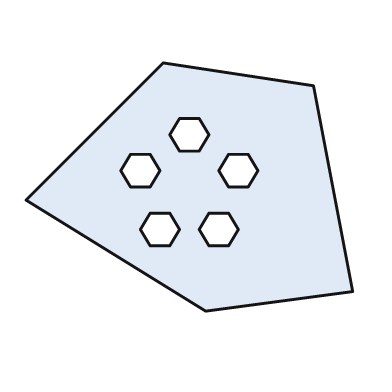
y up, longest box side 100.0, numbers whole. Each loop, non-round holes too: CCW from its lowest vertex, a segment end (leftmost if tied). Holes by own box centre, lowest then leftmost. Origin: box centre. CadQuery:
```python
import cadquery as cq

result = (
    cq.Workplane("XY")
    .moveTo(5.0, -38.0)
    .lineTo(50.0, -32.0)
    .lineTo(38.0, 31.0)
    .lineTo(-8.0, 38.0)
    .lineTo(-50.0, -4.0)
    .close()
    .moveTo(-12.0, -18.0)
    .lineTo(-6.0, -18.0)
    .lineTo(-3.0, -13.0)
    .lineTo(-6.0, -8.0)
    .lineTo(-12.0, -8.0)
    .lineTo(-15.0, -13.0)
    .close()
    .moveTo(6.0, -18.0)
    .lineTo(12.0, -18.0)
    .lineTo(15.0, -13.0)
    .lineTo(12.0, -8.0)
    .lineTo(6.0, -8.0)
    .lineTo(3.0, -13.0)
    .close()
    .moveTo(-18.0, 0.0)
    .lineTo(-12.0, 0.0)
    .lineTo(-9.0, 5.0)
    .lineTo(-12.0, 10.0)
    .lineTo(-18.0, 10.0)
    .lineTo(-21.0, 5.0)
    .close()
    .moveTo(12.0, 0.0)
    .lineTo(18.0, 0.0)
    .lineTo(21.0, 5.0)
    .lineTo(18.0, 10.0)
    .lineTo(12.0, 10.0)
    .lineTo(9.0, 5.0)
    .close()
    .moveTo(-3.0, 11.0)
    .lineTo(3.0, 11.0)
    .lineTo(6.0, 16.0)
    .lineTo(3.0, 21.0)
    .lineTo(-3.0, 21.0)
    .lineTo(-6.0, 16.0)
    .close()
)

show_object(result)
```